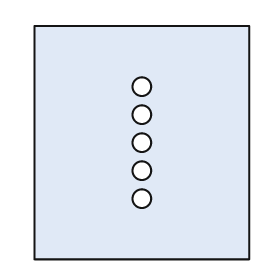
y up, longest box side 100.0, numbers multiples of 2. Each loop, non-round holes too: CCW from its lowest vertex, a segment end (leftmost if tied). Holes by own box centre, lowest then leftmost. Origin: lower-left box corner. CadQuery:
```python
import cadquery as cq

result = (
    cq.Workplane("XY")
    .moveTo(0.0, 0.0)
    .lineTo(92.0, 0.0)
    .lineTo(92.0, 100.0)
    .lineTo(0.0, 100.0)
    .close()
    .moveTo(46.0, 26.0)
    .circle(4.0)
    .moveTo(46.0, 38.0)
    .circle(4.0)
    .moveTo(46.0, 50.0)
    .circle(4.0)
    .moveTo(46.0, 62.0)
    .circle(4.0)
    .moveTo(46.0, 74.0)
    .circle(4.0)
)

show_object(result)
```